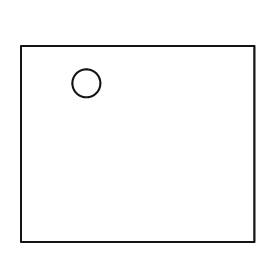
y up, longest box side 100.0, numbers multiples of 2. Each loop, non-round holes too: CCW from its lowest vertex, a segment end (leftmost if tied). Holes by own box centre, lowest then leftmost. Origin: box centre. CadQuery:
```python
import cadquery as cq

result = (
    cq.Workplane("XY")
    .moveTo(-50.0, -42.0)
    .lineTo(50.0, -42.0)
    .lineTo(50.0, 42.0)
    .lineTo(-50.0, 42.0)
    .close()
    .moveTo(-22.0, 26.0)
    .circle(6.0)
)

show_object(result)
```